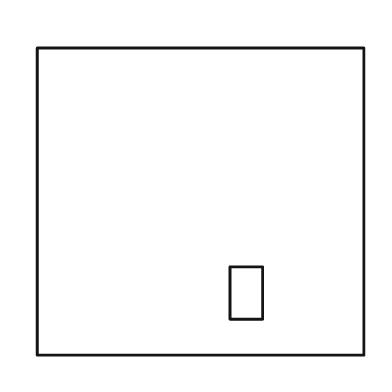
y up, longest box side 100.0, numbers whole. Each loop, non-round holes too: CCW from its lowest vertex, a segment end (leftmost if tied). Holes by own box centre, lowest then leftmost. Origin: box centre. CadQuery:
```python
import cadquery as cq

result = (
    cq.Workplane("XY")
    .moveTo(-50.0, -47.0)
    .lineTo(50.0, -47.0)
    .lineTo(50.0, 47.0)
    .lineTo(-50.0, 47.0)
    .close()
    .moveTo(9.0, -36.0)
    .lineTo(19.0, -36.0)
    .lineTo(19.0, -20.0)
    .lineTo(9.0, -20.0)
    .close()
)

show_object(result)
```